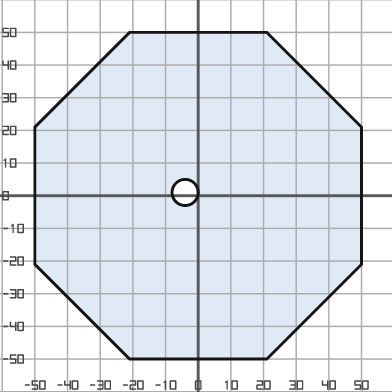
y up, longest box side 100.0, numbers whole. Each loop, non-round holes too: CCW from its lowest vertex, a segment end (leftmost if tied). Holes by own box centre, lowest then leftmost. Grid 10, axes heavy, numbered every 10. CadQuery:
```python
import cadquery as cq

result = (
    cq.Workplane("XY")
    .moveTo(-21.0, -50.0)
    .lineTo(21.0, -50.0)
    .lineTo(50.0, -21.0)
    .lineTo(50.0, 21.0)
    .lineTo(21.0, 50.0)
    .lineTo(-21.0, 50.0)
    .lineTo(-50.0, 21.0)
    .lineTo(-50.0, -21.0)
    .close()
    .moveTo(-4.0, 1.0)
    .circle(4.0)
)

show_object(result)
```